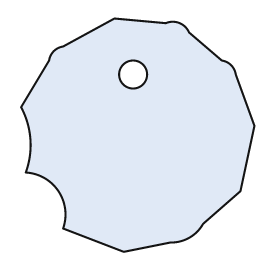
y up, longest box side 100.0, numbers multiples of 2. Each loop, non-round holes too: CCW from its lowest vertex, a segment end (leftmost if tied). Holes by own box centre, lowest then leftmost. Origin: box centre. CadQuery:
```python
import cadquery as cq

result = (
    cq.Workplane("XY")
    .moveTo(-6.0, -50.0)
    .lineTo(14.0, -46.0)
    .threePointArc((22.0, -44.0), (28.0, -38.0))
    .lineTo(44.0, -24.0)
    .lineTo(50.0, 4.0)
    .lineTo(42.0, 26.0)
    .threePointArc((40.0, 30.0), (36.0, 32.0))
    .lineTo(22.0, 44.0)
    .threePointArc((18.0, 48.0), (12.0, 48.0))
    .lineTo(-10.0, 50.0)
    .lineTo(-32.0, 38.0)
    .threePointArc((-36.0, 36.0), (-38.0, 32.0))
    .lineTo(-50.0, 12.0)
    .threePointArc((-46.0, -2.0), (-48.0, -16.0))
    .threePointArc((-34.0, -24.0), (-32.0, -40.0))
    .close()
    .moveTo(-2.0, 26.0)
    .circle(6.0)
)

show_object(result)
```